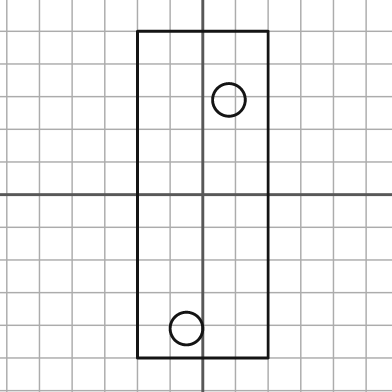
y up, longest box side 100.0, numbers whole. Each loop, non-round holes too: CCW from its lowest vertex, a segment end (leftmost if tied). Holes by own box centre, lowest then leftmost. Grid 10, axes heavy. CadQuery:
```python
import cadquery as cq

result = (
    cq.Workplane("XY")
    .moveTo(-20.0, -50.0)
    .lineTo(20.0, -50.0)
    .lineTo(20.0, 50.0)
    .lineTo(-20.0, 50.0)
    .close()
    .moveTo(-5.0, -41.0)
    .circle(5.0)
    .moveTo(8.0, 29.0)
    .circle(5.0)
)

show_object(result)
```